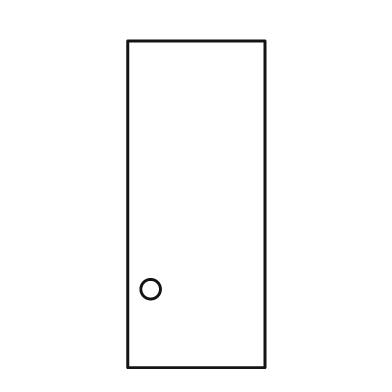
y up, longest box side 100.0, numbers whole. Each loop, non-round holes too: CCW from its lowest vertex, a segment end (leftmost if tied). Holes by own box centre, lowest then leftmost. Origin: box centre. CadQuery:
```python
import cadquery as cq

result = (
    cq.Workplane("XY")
    .moveTo(-21.0, -50.0)
    .lineTo(21.0, -50.0)
    .lineTo(21.0, 50.0)
    .lineTo(-21.0, 50.0)
    .close()
    .moveTo(-14.0, -26.0)
    .circle(3.0)
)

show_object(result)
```